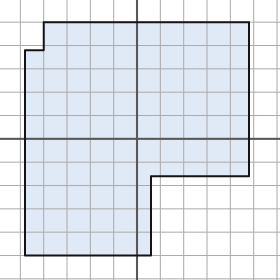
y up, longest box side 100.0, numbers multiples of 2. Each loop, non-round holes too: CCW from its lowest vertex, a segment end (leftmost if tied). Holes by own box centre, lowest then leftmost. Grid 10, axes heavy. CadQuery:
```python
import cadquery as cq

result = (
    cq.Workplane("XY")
    .moveTo(-48.0, -50.0)
    .lineTo(6.0, -50.0)
    .lineTo(6.0, -16.0)
    .lineTo(48.0, -16.0)
    .lineTo(48.0, 50.0)
    .lineTo(-40.0, 50.0)
    .lineTo(-40.0, 38.0)
    .lineTo(-48.0, 38.0)
    .close()
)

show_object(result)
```